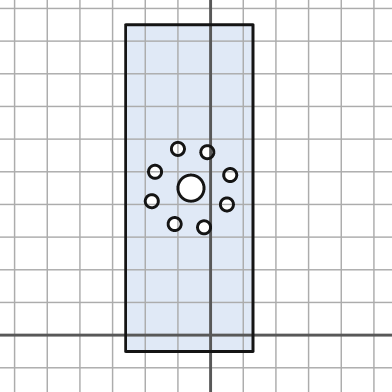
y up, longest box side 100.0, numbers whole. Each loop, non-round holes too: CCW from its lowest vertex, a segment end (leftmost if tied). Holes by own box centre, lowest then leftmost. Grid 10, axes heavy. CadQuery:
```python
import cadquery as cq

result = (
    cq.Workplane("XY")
    .moveTo(-26.0, -5.0)
    .lineTo(13.0, -5.0)
    .lineTo(13.0, 95.0)
    .lineTo(-26.0, 95.0)
    .close()
    .moveTo(-2.0, 33.0)
    .circle(2.0)
    .moveTo(-11.0, 34.0)
    .circle(2.0)
    .moveTo(5.0, 40.0)
    .circle(2.0)
    .moveTo(-18.0, 41.0)
    .circle(2.0)
    .moveTo(-6.0, 45.0)
    .circle(4.0)
    .moveTo(6.0, 49.0)
    .circle(2.0)
    .moveTo(-17.0, 50.0)
    .circle(2.0)
    .moveTo(-1.0, 56.0)
    .circle(2.0)
    .moveTo(-10.0, 57.0)
    .circle(2.0)
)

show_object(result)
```